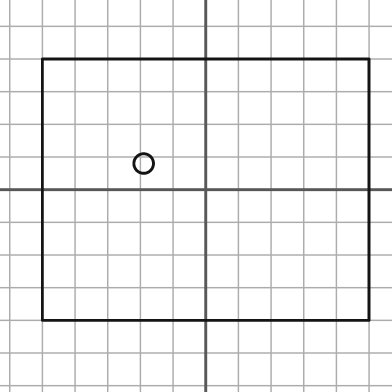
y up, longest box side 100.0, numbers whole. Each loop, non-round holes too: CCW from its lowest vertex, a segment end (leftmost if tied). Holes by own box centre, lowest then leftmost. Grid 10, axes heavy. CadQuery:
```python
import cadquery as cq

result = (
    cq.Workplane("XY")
    .moveTo(-50.0, -40.0)
    .lineTo(50.0, -40.0)
    .lineTo(50.0, 40.0)
    .lineTo(-50.0, 40.0)
    .close()
    .moveTo(-19.0, 8.0)
    .circle(3.0)
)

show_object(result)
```